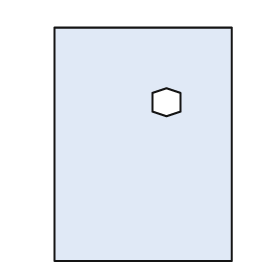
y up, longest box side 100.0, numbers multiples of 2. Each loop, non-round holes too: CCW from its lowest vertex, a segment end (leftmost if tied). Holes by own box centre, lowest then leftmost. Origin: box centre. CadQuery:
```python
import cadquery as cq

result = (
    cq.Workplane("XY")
    .moveTo(-38.0, -50.0)
    .lineTo(38.0, -50.0)
    .lineTo(38.0, 50.0)
    .lineTo(-38.0, 50.0)
    .close()
    .moveTo(10.0, 12.0)
    .lineTo(16.0, 14.0)
    .lineTo(16.0, 22.0)
    .lineTo(10.0, 24.0)
    .lineTo(4.0, 22.0)
    .lineTo(4.0, 14.0)
    .close()
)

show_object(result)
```